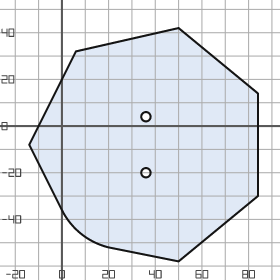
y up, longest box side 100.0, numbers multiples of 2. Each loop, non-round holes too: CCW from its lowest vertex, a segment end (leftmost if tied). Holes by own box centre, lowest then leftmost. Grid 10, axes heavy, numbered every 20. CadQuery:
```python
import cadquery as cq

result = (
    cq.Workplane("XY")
    .moveTo(50.0, -58.0)
    .lineTo(84.0, -30.0)
    .lineTo(84.0, 14.0)
    .lineTo(50.0, 42.0)
    .lineTo(6.0, 32.0)
    .lineTo(-14.0, -8.0)
    .lineTo(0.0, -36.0)
    .threePointArc((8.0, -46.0), (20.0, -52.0))
    .close()
    .moveTo(36.0, -20.0)
    .circle(2.0)
    .moveTo(36.0, 4.0)
    .circle(2.0)
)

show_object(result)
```